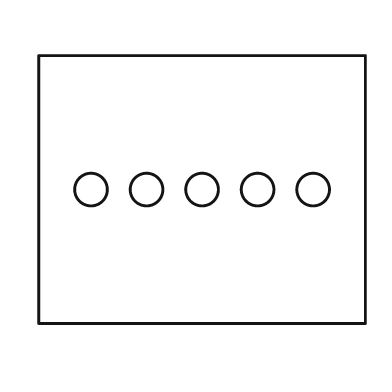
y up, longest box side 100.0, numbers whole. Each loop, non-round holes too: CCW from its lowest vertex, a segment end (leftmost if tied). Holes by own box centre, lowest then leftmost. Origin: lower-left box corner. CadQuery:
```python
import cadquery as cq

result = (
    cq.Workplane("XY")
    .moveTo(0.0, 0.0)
    .lineTo(100.0, 0.0)
    .lineTo(100.0, 82.0)
    .lineTo(0.0, 82.0)
    .close()
    .moveTo(16.0, 41.0)
    .circle(5.0)
    .moveTo(33.0, 41.0)
    .circle(5.0)
    .moveTo(50.0, 41.0)
    .circle(5.0)
    .moveTo(67.0, 41.0)
    .circle(5.0)
    .moveTo(84.0, 41.0)
    .circle(5.0)
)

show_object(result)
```